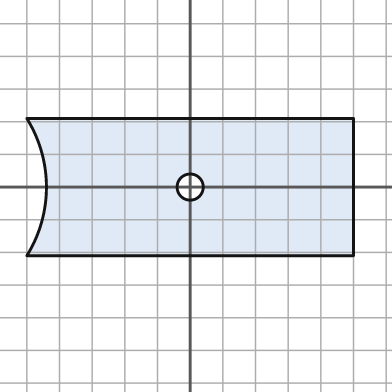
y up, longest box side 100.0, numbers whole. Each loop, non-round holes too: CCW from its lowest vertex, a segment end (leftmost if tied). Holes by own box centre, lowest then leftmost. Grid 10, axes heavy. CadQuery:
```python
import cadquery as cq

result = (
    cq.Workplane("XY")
    .moveTo(-50.0, -21.0)
    .lineTo(50.0, -21.0)
    .lineTo(50.0, 21.0)
    .lineTo(-50.0, 21.0)
    .threePointArc((-44.0, 0.0), (-50.0, -21.0))
    .close()
    .moveTo(0.0, 0.0)
    .circle(4.0)
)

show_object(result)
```